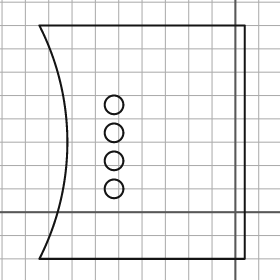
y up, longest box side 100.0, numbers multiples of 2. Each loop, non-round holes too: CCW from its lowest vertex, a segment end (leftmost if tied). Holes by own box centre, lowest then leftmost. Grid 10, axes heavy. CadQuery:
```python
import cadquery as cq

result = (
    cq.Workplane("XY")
    .moveTo(-84.0, -20.0)
    .lineTo(4.0, -20.0)
    .lineTo(4.0, 80.0)
    .lineTo(-84.0, 80.0)
    .threePointArc((-72.0, 30.0), (-84.0, -20.0))
    .close()
    .moveTo(-52.0, 10.0)
    .circle(4.0)
    .moveTo(-52.0, 22.0)
    .circle(4.0)
    .moveTo(-52.0, 34.0)
    .circle(4.0)
    .moveTo(-52.0, 46.0)
    .circle(4.0)
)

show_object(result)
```